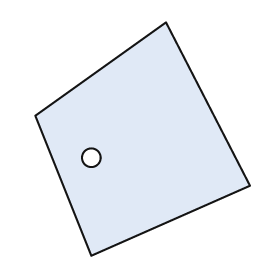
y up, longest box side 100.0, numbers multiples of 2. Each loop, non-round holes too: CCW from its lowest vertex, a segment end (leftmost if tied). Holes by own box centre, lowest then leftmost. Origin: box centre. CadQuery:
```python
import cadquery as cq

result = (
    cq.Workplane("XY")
    .moveTo(-22.0, -50.0)
    .lineTo(46.0, -20.0)
    .lineTo(10.0, 50.0)
    .lineTo(-46.0, 10.0)
    .close()
    .moveTo(-22.0, -8.0)
    .circle(4.0)
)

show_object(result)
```